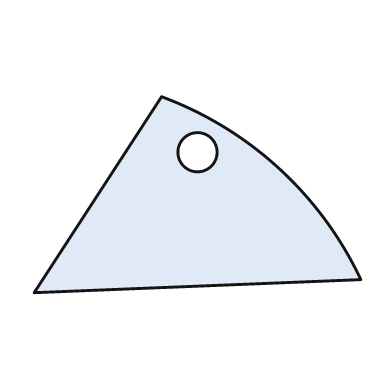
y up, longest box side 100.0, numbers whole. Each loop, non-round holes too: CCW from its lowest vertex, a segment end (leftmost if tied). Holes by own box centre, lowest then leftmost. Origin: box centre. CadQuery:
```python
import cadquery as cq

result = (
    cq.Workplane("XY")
    .moveTo(-50.0, -30.0)
    .lineTo(50.0, -26.0)
    .threePointArc((25.0, 8.0), (-11.0, 30.0))
    .close()
    .moveTo(0.0, 13.0)
    .circle(6.0)
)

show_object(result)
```